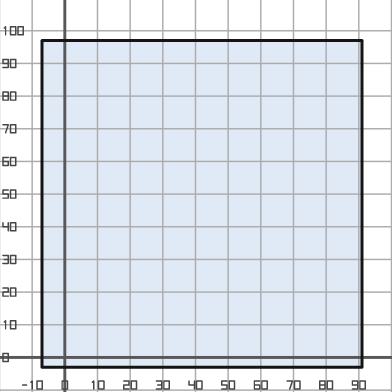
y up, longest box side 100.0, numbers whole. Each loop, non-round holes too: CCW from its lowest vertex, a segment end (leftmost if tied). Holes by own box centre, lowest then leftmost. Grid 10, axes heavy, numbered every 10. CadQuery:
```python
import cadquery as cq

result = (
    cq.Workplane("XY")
    .moveTo(-7.0, -3.0)
    .lineTo(91.0, -3.0)
    .lineTo(91.0, 97.0)
    .lineTo(-7.0, 97.0)
    .close()
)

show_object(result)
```